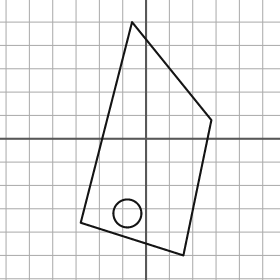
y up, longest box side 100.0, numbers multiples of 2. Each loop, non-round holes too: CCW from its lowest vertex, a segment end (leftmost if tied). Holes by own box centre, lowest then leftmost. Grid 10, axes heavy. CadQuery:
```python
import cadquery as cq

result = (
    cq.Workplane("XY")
    .moveTo(16.0, -50.0)
    .lineTo(28.0, 8.0)
    .lineTo(-6.0, 50.0)
    .lineTo(-28.0, -36.0)
    .close()
    .moveTo(-8.0, -32.0)
    .circle(6.0)
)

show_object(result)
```